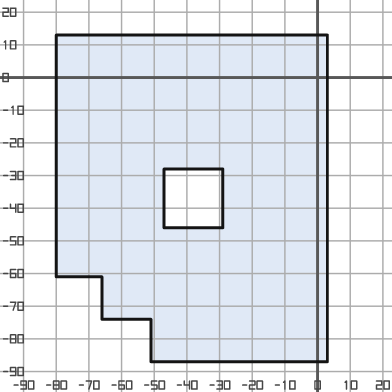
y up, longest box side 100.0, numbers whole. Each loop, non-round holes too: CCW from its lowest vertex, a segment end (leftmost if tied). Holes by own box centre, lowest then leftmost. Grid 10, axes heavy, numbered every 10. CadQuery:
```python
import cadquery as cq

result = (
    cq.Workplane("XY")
    .moveTo(-51.0, -87.0)
    .lineTo(3.0, -87.0)
    .lineTo(3.0, 13.0)
    .lineTo(-80.0, 13.0)
    .lineTo(-80.0, -61.0)
    .lineTo(-66.0, -61.0)
    .lineTo(-66.0, -74.0)
    .lineTo(-51.0, -74.0)
    .close()
    .moveTo(-47.0, -46.0)
    .lineTo(-29.0, -46.0)
    .lineTo(-29.0, -28.0)
    .lineTo(-47.0, -28.0)
    .close()
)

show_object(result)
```